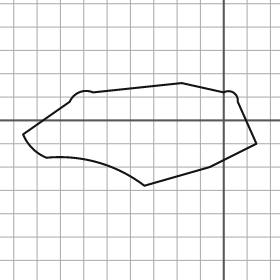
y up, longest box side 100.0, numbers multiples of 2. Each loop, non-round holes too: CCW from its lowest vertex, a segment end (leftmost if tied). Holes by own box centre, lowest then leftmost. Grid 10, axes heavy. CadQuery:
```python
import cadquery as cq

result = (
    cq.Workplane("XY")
    .moveTo(-34.0, -28.0)
    .lineTo(-6.0, -20.0)
    .lineTo(14.0, -10.0)
    .lineTo(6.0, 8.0)
    .threePointArc((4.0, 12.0), (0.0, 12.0))
    .lineTo(-18.0, 16.0)
    .lineTo(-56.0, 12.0)
    .threePointArc((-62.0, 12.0), (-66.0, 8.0))
    .lineTo(-86.0, -6.0)
    .threePointArc((-82.0, -12.0), (-76.0, -16.0))
    .threePointArc((-54.0, -18.0), (-34.0, -28.0))
    .close()
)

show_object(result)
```